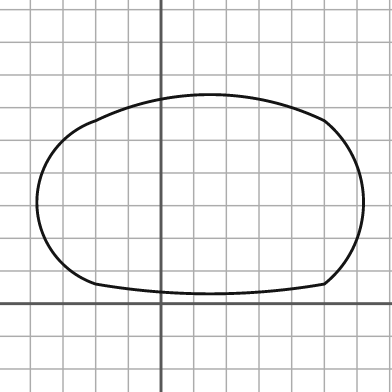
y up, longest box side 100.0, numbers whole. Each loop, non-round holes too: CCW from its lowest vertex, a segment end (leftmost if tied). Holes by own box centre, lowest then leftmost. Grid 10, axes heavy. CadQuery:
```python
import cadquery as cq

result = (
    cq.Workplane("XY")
    .moveTo(-20.0, 6.0)
    .threePointArc((15.0, 3.0), (50.0, 6.0))
    .threePointArc((62.0, 31.0), (50.0, 56.0))
    .threePointArc((15.0, 64.0), (-20.0, 56.0))
    .threePointArc((-38.0, 31.0), (-20.0, 6.0))
    .close()
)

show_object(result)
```